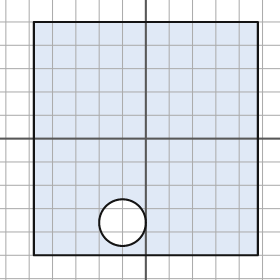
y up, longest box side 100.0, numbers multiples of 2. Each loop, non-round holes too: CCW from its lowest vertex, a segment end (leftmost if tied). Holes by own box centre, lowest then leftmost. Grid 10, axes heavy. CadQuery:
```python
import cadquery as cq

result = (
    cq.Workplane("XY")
    .moveTo(-48.0, -50.0)
    .lineTo(48.0, -50.0)
    .lineTo(48.0, 50.0)
    .lineTo(-48.0, 50.0)
    .close()
    .moveTo(-10.0, -36.0)
    .circle(10.0)
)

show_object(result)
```